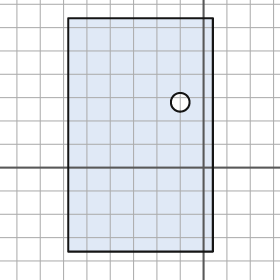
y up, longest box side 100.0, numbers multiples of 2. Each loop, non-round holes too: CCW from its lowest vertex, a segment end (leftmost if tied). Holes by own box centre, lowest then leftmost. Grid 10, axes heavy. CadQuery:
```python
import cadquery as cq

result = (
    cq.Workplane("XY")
    .moveTo(-58.0, -36.0)
    .lineTo(4.0, -36.0)
    .lineTo(4.0, 64.0)
    .lineTo(-58.0, 64.0)
    .close()
    .moveTo(-10.0, 28.0)
    .circle(4.0)
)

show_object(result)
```